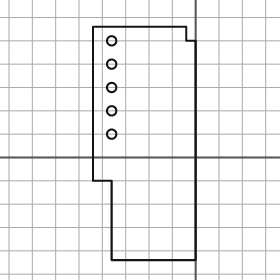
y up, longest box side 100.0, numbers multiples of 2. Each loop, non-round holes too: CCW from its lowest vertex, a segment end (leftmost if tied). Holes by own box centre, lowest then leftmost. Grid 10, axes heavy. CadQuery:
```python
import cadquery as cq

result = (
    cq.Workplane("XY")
    .moveTo(-36.0, -44.0)
    .lineTo(0.0, -44.0)
    .lineTo(0.0, 50.0)
    .lineTo(-4.0, 50.0)
    .lineTo(-4.0, 56.0)
    .lineTo(-44.0, 56.0)
    .lineTo(-44.0, -10.0)
    .lineTo(-36.0, -10.0)
    .close()
    .moveTo(-36.0, 10.0)
    .circle(2.0)
    .moveTo(-36.0, 20.0)
    .circle(2.0)
    .moveTo(-36.0, 30.0)
    .circle(2.0)
    .moveTo(-36.0, 40.0)
    .circle(2.0)
    .moveTo(-36.0, 50.0)
    .circle(2.0)
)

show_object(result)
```